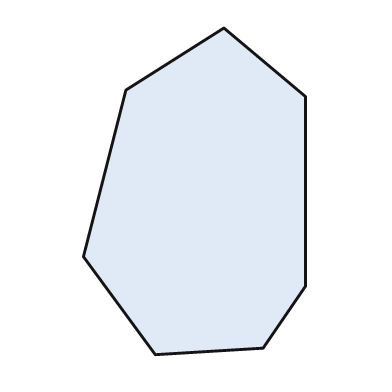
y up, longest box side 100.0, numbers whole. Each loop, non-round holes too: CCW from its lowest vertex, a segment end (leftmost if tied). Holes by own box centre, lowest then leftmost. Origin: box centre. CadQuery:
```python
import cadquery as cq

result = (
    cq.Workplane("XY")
    .moveTo(-12.0, -50.0)
    .lineTo(21.0, -48.0)
    .lineTo(34.0, -29.0)
    .lineTo(34.0, 29.0)
    .lineTo(9.0, 50.0)
    .lineTo(-21.0, 31.0)
    .lineTo(-34.0, -20.0)
    .close()
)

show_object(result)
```